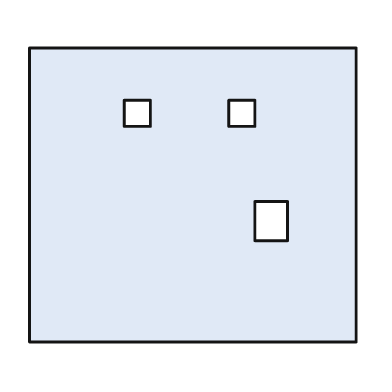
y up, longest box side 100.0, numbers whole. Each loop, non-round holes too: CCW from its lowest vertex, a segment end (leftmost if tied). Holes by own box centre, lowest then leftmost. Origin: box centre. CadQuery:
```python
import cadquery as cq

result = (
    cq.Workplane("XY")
    .moveTo(-50.0, -45.0)
    .lineTo(50.0, -45.0)
    .lineTo(50.0, 45.0)
    .lineTo(-50.0, 45.0)
    .close()
    .moveTo(19.0, -14.0)
    .lineTo(29.0, -14.0)
    .lineTo(29.0, -2.0)
    .lineTo(19.0, -2.0)
    .close()
    .moveTo(-21.0, 21.0)
    .lineTo(-13.0, 21.0)
    .lineTo(-13.0, 29.0)
    .lineTo(-21.0, 29.0)
    .close()
    .moveTo(11.0, 21.0)
    .lineTo(19.0, 21.0)
    .lineTo(19.0, 29.0)
    .lineTo(11.0, 29.0)
    .close()
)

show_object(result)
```